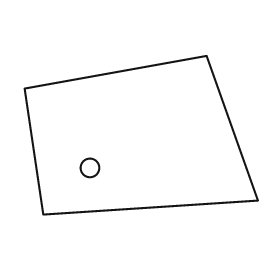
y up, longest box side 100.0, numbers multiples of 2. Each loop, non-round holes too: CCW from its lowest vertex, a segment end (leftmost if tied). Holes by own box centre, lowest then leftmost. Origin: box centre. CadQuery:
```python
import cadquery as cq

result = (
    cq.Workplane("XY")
    .moveTo(-42.0, -34.0)
    .lineTo(50.0, -28.0)
    .lineTo(28.0, 34.0)
    .lineTo(-50.0, 20.0)
    .close()
    .moveTo(-22.0, -14.0)
    .circle(4.0)
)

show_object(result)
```